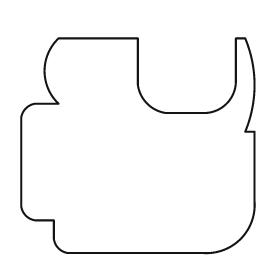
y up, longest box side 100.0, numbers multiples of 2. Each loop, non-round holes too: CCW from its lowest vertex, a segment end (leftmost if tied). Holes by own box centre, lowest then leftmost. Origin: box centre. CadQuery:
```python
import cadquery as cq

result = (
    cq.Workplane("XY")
    .moveTo(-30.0, -46.0)
    .lineTo(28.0, -46.0)
    .threePointArc((44.0, -40.0), (50.0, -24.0))
    .lineTo(50.0, 6.0)
    .lineTo(46.0, 6.0)
    .threePointArc((50.0, 26.0), (46.0, 46.0))
    .lineTo(42.0, 46.0)
    .lineTo(42.0, 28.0)
    .threePointArc((38.0, 18.0), (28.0, 14.0))
    .lineTo(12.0, 14.0)
    .threePointArc((4.0, 18.0), (0.0, 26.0))
    .lineTo(0.0, 46.0)
    .lineTo(-34.0, 46.0)
    .threePointArc((-40.0, 32.0), (-34.0, 18.0))
    .lineTo(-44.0, 18.0)
    .threePointArc((-48.0, 16.0), (-50.0, 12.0))
    .lineTo(-50.0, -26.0)
    .threePointArc((-48.0, -30.0), (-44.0, -32.0))
    .lineTo(-36.0, -32.0)
    .lineTo(-36.0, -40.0)
    .threePointArc((-34.0, -44.0), (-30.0, -46.0))
    .close()
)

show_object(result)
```